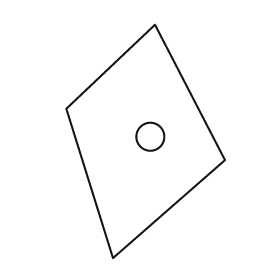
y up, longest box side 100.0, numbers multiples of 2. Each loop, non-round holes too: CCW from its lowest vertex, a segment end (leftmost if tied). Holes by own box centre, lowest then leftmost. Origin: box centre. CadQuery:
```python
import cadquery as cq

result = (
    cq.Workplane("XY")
    .moveTo(-14.0, -50.0)
    .lineTo(34.0, -8.0)
    .lineTo(4.0, 50.0)
    .lineTo(-34.0, 14.0)
    .close()
    .moveTo(2.0, 2.0)
    .circle(6.0)
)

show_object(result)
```